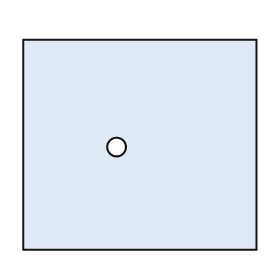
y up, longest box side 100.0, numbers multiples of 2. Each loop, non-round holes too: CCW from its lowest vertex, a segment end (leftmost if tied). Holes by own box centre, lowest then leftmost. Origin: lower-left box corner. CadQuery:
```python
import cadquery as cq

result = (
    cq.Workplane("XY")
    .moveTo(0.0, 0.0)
    .lineTo(100.0, 0.0)
    .lineTo(100.0, 90.0)
    .lineTo(0.0, 90.0)
    .close()
    .moveTo(40.0, 44.0)
    .circle(4.0)
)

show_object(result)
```